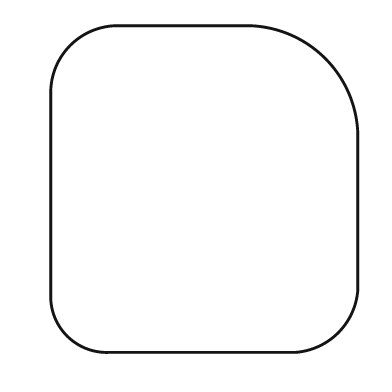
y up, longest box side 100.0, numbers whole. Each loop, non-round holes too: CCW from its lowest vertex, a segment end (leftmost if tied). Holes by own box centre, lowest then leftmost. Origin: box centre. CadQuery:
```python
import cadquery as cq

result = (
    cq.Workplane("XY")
    .moveTo(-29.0, -50.0)
    .lineTo(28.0, -50.0)
    .threePointArc((41.0, -44.0), (47.0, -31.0))
    .lineTo(47.0, 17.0)
    .threePointArc((37.0, 40.0), (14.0, 50.0))
    .lineTo(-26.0, 50.0)
    .threePointArc((-41.0, 44.0), (-47.0, 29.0))
    .lineTo(-47.0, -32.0)
    .threePointArc((-42.0, -45.0), (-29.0, -50.0))
    .close()
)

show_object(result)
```